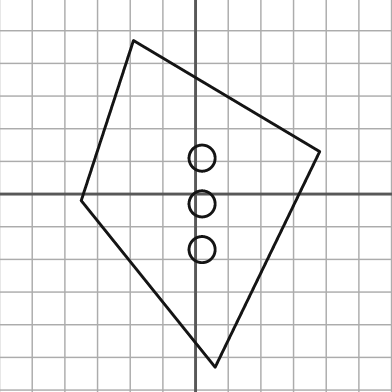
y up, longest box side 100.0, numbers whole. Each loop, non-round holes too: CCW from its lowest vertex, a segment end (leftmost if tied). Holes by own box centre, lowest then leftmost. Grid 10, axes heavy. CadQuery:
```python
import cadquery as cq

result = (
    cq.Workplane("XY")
    .moveTo(6.0, -53.0)
    .lineTo(38.0, 13.0)
    .lineTo(-19.0, 47.0)
    .lineTo(-35.0, -2.0)
    .close()
    .moveTo(2.0, -17.0)
    .circle(4.0)
    .moveTo(2.0, -3.0)
    .circle(4.0)
    .moveTo(2.0, 11.0)
    .circle(4.0)
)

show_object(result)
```